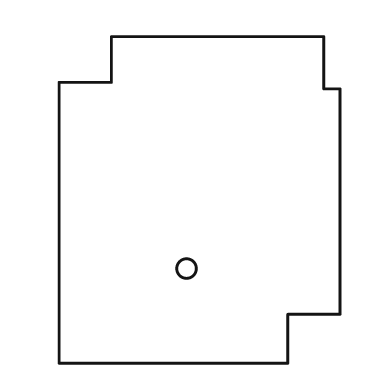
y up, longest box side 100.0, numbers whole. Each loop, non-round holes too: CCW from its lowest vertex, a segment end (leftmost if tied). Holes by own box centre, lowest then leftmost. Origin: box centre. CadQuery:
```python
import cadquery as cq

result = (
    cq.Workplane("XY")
    .moveTo(-43.0, -50.0)
    .lineTo(27.0, -50.0)
    .lineTo(27.0, -35.0)
    .lineTo(43.0, -35.0)
    .lineTo(43.0, 34.0)
    .lineTo(38.0, 34.0)
    .lineTo(38.0, 50.0)
    .lineTo(-27.0, 50.0)
    .lineTo(-27.0, 36.0)
    .lineTo(-43.0, 36.0)
    .close()
    .moveTo(-4.0, -21.0)
    .circle(3.0)
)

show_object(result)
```